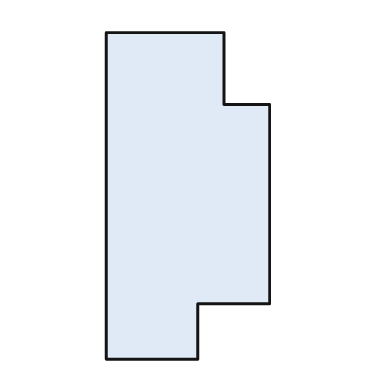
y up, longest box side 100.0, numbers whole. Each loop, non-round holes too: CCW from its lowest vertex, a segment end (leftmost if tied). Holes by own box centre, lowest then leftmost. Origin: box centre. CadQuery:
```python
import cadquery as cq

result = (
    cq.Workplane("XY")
    .moveTo(-25.0, -50.0)
    .lineTo(3.0, -50.0)
    .lineTo(3.0, -33.0)
    .lineTo(25.0, -33.0)
    .lineTo(25.0, 28.0)
    .lineTo(11.0, 28.0)
    .lineTo(11.0, 50.0)
    .lineTo(-25.0, 50.0)
    .close()
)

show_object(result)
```